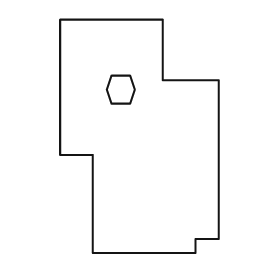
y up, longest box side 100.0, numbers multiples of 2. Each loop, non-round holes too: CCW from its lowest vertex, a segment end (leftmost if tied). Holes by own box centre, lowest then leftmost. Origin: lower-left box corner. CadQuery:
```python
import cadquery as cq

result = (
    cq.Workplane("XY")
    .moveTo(14.0, 0.0)
    .lineTo(58.0, 0.0)
    .lineTo(58.0, 6.0)
    .lineTo(68.0, 6.0)
    .lineTo(68.0, 74.0)
    .lineTo(44.0, 74.0)
    .lineTo(44.0, 100.0)
    .lineTo(0.0, 100.0)
    .lineTo(0.0, 42.0)
    .lineTo(14.0, 42.0)
    .close()
    .moveTo(22.0, 64.0)
    .lineTo(30.0, 64.0)
    .lineTo(32.0, 70.0)
    .lineTo(30.0, 76.0)
    .lineTo(22.0, 76.0)
    .lineTo(20.0, 70.0)
    .close()
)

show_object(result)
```